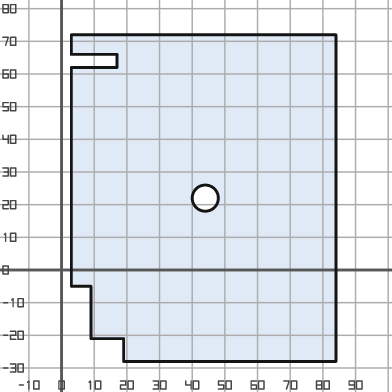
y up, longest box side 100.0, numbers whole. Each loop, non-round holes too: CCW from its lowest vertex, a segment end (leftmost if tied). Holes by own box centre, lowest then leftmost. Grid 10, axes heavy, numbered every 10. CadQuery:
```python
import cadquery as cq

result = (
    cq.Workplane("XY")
    .moveTo(19.0, -28.0)
    .lineTo(84.0, -28.0)
    .lineTo(84.0, 72.0)
    .lineTo(3.0, 72.0)
    .lineTo(3.0, 66.0)
    .lineTo(17.0, 66.0)
    .lineTo(17.0, 62.0)
    .lineTo(3.0, 62.0)
    .lineTo(3.0, -5.0)
    .lineTo(9.0, -5.0)
    .lineTo(9.0, -21.0)
    .lineTo(19.0, -21.0)
    .close()
    .moveTo(44.0, 22.0)
    .circle(4.0)
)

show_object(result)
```